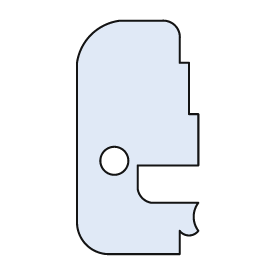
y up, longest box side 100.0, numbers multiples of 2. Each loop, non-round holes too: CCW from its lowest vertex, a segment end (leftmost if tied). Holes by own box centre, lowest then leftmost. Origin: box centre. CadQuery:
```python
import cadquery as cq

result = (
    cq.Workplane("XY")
    .moveTo(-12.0, -50.0)
    .lineTo(18.0, -50.0)
    .lineTo(18.0, -40.0)
    .threePointArc((22.0, -42.0), (26.0, -40.0))
    .threePointArc((24.0, -34.0), (26.0, -28.0))
    .lineTo(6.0, -28.0)
    .threePointArc((2.0, -26.0), (0.0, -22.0))
    .lineTo(0.0, -12.0)
    .lineTo(26.0, -12.0)
    .lineTo(26.0, 10.0)
    .lineTo(22.0, 10.0)
    .lineTo(22.0, 32.0)
    .lineTo(18.0, 32.0)
    .lineTo(18.0, 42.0)
    .threePointArc((16.0, 48.0), (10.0, 50.0))
    .lineTo(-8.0, 50.0)
    .threePointArc((-20.0, 44.0), (-26.0, 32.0))
    .lineTo(-26.0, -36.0)
    .threePointArc((-22.0, -46.0), (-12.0, -50.0))
    .close()
    .moveTo(-10.0, -10.0)
    .circle(6.0)
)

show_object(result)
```